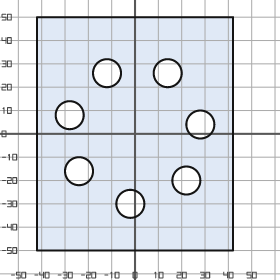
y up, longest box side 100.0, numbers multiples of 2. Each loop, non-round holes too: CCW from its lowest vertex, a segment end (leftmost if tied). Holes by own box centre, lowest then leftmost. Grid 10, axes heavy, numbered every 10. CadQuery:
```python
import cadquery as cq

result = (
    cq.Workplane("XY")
    .moveTo(-42.0, -50.0)
    .lineTo(42.0, -50.0)
    .lineTo(42.0, 50.0)
    .lineTo(-42.0, 50.0)
    .close()
    .moveTo(-2.0, -30.0)
    .circle(6.0)
    .moveTo(22.0, -20.0)
    .circle(6.0)
    .moveTo(-24.0, -16.0)
    .circle(6.0)
    .moveTo(28.0, 4.0)
    .circle(6.0)
    .moveTo(-28.0, 8.0)
    .circle(6.0)
    .moveTo(-12.0, 26.0)
    .circle(6.0)
    .moveTo(14.0, 26.0)
    .circle(6.0)
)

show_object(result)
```